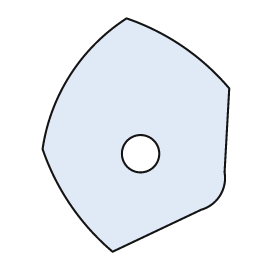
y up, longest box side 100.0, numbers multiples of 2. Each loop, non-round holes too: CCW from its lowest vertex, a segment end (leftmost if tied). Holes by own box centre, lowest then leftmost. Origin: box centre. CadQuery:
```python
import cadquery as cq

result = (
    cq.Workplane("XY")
    .moveTo(-10.0, -50.0)
    .lineTo(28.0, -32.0)
    .threePointArc((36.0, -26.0), (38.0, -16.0))
    .lineTo(40.0, 20.0)
    .threePointArc((20.0, 38.0), (-4.0, 50.0))
    .threePointArc((-28.0, 26.0), (-40.0, -6.0))
    .threePointArc((-28.0, -30.0), (-10.0, -50.0))
    .close()
    .moveTo(2.0, -8.0)
    .circle(8.0)
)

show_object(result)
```